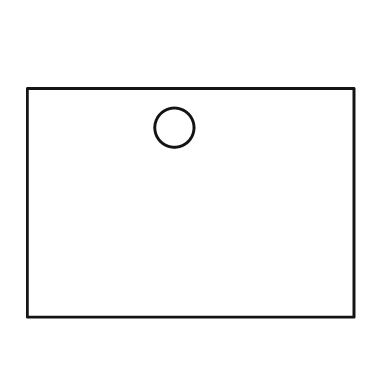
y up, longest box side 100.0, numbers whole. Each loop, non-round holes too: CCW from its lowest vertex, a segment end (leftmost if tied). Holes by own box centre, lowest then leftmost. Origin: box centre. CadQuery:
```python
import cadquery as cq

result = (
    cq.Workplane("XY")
    .moveTo(-50.0, -35.0)
    .lineTo(50.0, -35.0)
    .lineTo(50.0, 35.0)
    .lineTo(-50.0, 35.0)
    .close()
    .moveTo(-5.0, 23.0)
    .circle(6.0)
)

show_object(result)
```